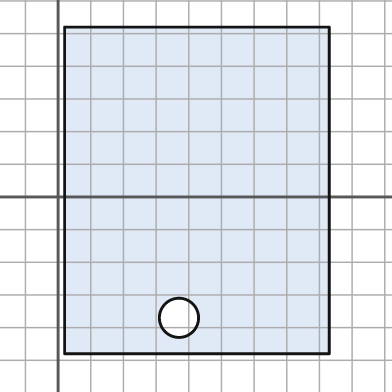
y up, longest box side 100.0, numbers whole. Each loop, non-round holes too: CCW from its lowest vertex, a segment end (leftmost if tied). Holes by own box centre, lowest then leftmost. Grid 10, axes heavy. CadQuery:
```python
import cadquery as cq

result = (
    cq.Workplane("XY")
    .moveTo(2.0, -48.0)
    .lineTo(83.0, -48.0)
    .lineTo(83.0, 52.0)
    .lineTo(2.0, 52.0)
    .close()
    .moveTo(37.0, -37.0)
    .circle(6.0)
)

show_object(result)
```